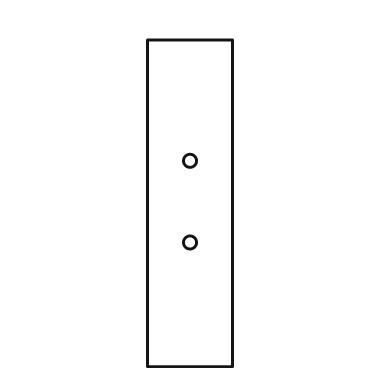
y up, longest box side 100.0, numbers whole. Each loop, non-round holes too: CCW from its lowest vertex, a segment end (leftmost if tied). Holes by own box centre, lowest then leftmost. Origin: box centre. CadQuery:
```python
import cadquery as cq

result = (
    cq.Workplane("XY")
    .moveTo(-13.0, -50.0)
    .lineTo(13.0, -50.0)
    .lineTo(13.0, 50.0)
    .lineTo(-13.0, 50.0)
    .close()
    .moveTo(0.0, -12.0)
    .circle(2.0)
    .moveTo(0.0, 13.0)
    .circle(2.0)
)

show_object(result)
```